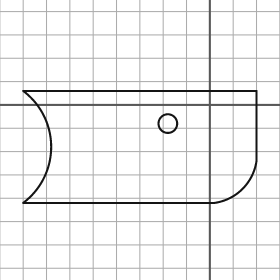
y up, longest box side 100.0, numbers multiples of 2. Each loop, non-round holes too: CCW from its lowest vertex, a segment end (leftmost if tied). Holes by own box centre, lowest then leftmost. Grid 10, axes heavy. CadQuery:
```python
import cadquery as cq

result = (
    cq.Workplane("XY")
    .moveTo(-80.0, -42.0)
    .lineTo(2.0, -42.0)
    .threePointArc((14.0, -36.0), (20.0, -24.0))
    .lineTo(20.0, 6.0)
    .lineTo(-80.0, 6.0)
    .threePointArc((-68.0, -18.0), (-80.0, -42.0))
    .close()
    .moveTo(-18.0, -8.0)
    .circle(4.0)
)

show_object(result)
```